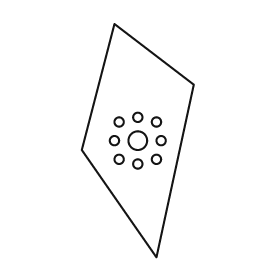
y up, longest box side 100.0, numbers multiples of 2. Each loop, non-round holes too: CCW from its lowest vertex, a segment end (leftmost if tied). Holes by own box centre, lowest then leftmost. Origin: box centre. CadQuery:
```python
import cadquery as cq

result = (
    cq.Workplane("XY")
    .moveTo(8.0, -50.0)
    .lineTo(24.0, 24.0)
    .lineTo(-10.0, 50.0)
    .lineTo(-24.0, -4.0)
    .close()
    .moveTo(0.0, -10.0)
    .circle(2.0)
    .moveTo(-8.0, -8.0)
    .circle(2.0)
    .moveTo(8.0, -8.0)
    .circle(2.0)
    .moveTo(-10.0, 0.0)
    .circle(2.0)
    .moveTo(0.0, 0.0)
    .circle(4.0)
    .moveTo(10.0, 0.0)
    .circle(2.0)
    .moveTo(-8.0, 8.0)
    .circle(2.0)
    .moveTo(8.0, 8.0)
    .circle(2.0)
    .moveTo(0.0, 10.0)
    .circle(2.0)
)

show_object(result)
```